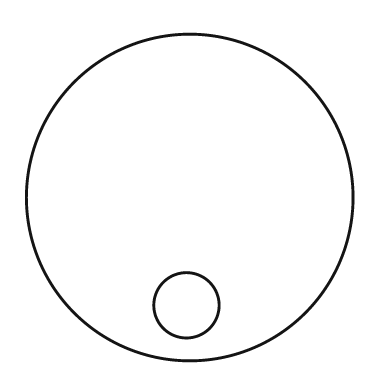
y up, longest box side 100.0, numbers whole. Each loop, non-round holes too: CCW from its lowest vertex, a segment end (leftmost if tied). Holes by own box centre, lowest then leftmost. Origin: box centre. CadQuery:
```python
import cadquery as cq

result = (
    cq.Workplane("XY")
    .moveTo(0.0, 0.0)
    .circle(50.0)
    .moveTo(-1.0, -33.0)
    .circle(10.0)
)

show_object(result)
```